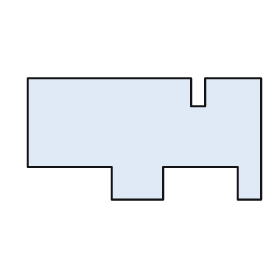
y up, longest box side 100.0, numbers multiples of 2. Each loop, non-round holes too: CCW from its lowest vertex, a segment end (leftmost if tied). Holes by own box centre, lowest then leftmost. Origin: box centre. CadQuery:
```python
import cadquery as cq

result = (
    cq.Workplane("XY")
    .moveTo(-14.0, -26.0)
    .lineTo(8.0, -26.0)
    .lineTo(8.0, -12.0)
    .lineTo(40.0, -12.0)
    .lineTo(40.0, -26.0)
    .lineTo(50.0, -26.0)
    .lineTo(50.0, 26.0)
    .lineTo(26.0, 26.0)
    .lineTo(26.0, 14.0)
    .lineTo(20.0, 14.0)
    .lineTo(20.0, 26.0)
    .lineTo(-50.0, 26.0)
    .lineTo(-50.0, -12.0)
    .lineTo(-14.0, -12.0)
    .close()
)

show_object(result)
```